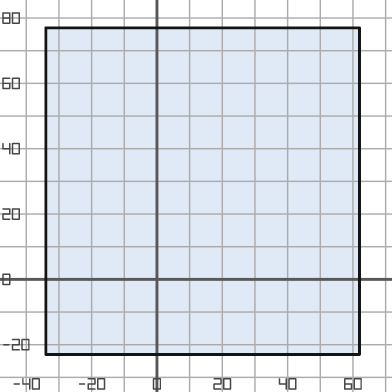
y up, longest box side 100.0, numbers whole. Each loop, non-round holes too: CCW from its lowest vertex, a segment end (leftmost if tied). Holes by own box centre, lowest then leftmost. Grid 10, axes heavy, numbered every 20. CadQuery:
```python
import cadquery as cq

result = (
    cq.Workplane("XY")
    .moveTo(-34.0, -23.0)
    .lineTo(62.0, -23.0)
    .lineTo(62.0, 77.0)
    .lineTo(-34.0, 77.0)
    .close()
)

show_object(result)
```